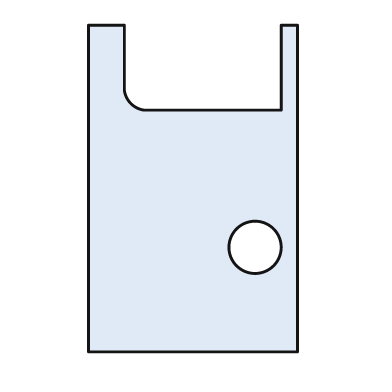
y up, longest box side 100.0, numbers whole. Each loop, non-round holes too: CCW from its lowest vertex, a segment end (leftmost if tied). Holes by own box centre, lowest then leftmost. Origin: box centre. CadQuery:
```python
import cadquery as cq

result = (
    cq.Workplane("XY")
    .moveTo(-32.0, -50.0)
    .lineTo(32.0, -50.0)
    .lineTo(32.0, 50.0)
    .lineTo(27.0, 50.0)
    .lineTo(27.0, 24.0)
    .lineTo(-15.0, 24.0)
    .threePointArc((-19.0, 26.0), (-21.0, 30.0))
    .lineTo(-21.0, 50.0)
    .lineTo(-32.0, 50.0)
    .close()
    .moveTo(19.0, -18.0)
    .circle(8.0)
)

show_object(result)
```